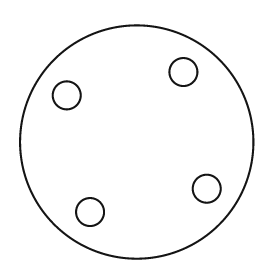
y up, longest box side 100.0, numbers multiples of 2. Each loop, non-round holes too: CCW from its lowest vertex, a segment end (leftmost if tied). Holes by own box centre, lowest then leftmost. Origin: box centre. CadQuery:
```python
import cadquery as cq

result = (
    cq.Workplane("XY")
    .moveTo(0.0, 0.0)
    .circle(50.0)
    .moveTo(-20.0, -30.0)
    .circle(6.0)
    .moveTo(30.0, -20.0)
    .circle(6.0)
    .moveTo(-30.0, 20.0)
    .circle(6.0)
    .moveTo(20.0, 30.0)
    .circle(6.0)
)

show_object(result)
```